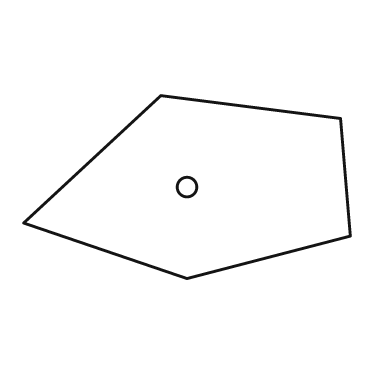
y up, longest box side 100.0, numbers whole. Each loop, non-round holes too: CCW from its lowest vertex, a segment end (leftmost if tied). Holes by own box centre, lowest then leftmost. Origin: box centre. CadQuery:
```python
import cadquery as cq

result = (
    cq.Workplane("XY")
    .moveTo(0.0, -28.0)
    .lineTo(50.0, -15.0)
    .lineTo(47.0, 21.0)
    .lineTo(-8.0, 28.0)
    .lineTo(-50.0, -11.0)
    .close()
    .moveTo(0.0, 0.0)
    .circle(3.0)
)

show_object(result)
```